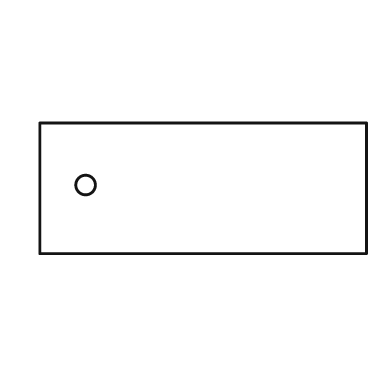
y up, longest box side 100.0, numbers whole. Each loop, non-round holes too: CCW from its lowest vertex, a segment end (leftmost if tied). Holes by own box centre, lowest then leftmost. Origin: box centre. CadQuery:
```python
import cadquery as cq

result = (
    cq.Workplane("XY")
    .moveTo(-50.0, -20.0)
    .lineTo(50.0, -20.0)
    .lineTo(50.0, 20.0)
    .lineTo(-50.0, 20.0)
    .close()
    .moveTo(-36.0, 1.0)
    .circle(3.0)
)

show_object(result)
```